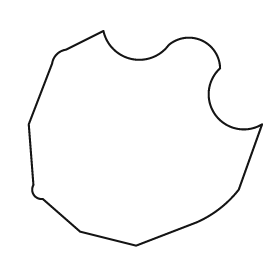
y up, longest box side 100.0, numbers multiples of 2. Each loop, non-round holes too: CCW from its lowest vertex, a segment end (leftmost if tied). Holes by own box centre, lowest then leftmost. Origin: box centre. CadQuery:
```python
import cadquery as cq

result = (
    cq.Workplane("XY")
    .moveTo(-4.0, -46.0)
    .lineTo(22.0, -36.0)
    .threePointArc((32.0, -30.0), (40.0, -22.0))
    .lineTo(50.0, 6.0)
    .threePointArc((30.0, 10.0), (32.0, 30.0))
    .threePointArc((24.0, 42.0), (10.0, 40.0))
    .threePointArc((-6.0, 34.0), (-18.0, 46.0))
    .lineTo(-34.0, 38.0)
    .threePointArc((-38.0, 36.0), (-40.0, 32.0))
    .lineTo(-50.0, 6.0)
    .lineTo(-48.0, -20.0)
    .threePointArc((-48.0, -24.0), (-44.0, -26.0))
    .lineTo(-28.0, -40.0)
    .close()
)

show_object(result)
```